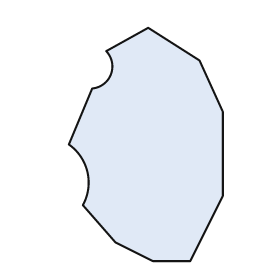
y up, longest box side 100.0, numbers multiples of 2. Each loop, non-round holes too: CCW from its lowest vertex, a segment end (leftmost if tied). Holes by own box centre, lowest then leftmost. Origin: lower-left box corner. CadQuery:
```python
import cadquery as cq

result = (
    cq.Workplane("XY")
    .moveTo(36.0, 0.0)
    .lineTo(52.0, 0.0)
    .lineTo(66.0, 28.0)
    .lineTo(66.0, 64.0)
    .lineTo(56.0, 86.0)
    .lineTo(34.0, 100.0)
    .lineTo(16.0, 90.0)
    .threePointArc((18.0, 80.0), (10.0, 74.0))
    .lineTo(0.0, 50.0)
    .threePointArc((8.0, 38.0), (6.0, 24.0))
    .lineTo(20.0, 8.0)
    .close()
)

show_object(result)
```